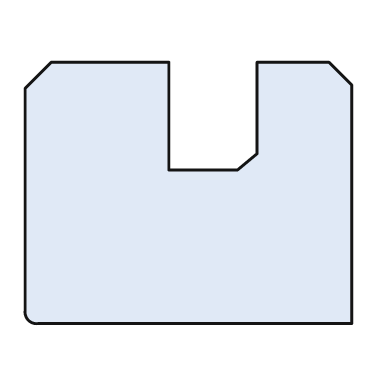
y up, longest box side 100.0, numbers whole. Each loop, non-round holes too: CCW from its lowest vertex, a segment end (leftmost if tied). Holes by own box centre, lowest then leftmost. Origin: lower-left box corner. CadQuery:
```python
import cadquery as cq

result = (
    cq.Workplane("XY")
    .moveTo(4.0, 0.0)
    .lineTo(100.0, 0.0)
    .lineTo(100.0, 73.0)
    .lineTo(93.0, 80.0)
    .lineTo(71.0, 80.0)
    .lineTo(71.0, 52.0)
    .lineTo(65.0, 47.0)
    .lineTo(44.0, 47.0)
    .lineTo(44.0, 80.0)
    .lineTo(8.0, 80.0)
    .lineTo(0.0, 72.0)
    .lineTo(0.0, 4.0)
    .threePointArc((1.0, 1.0), (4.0, 0.0))
    .close()
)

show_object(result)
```